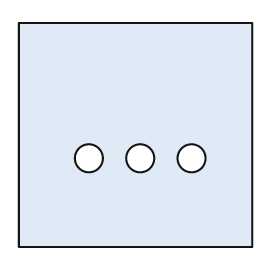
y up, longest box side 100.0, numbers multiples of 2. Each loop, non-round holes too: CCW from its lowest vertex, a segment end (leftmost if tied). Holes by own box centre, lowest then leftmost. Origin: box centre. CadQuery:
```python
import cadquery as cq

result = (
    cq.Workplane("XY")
    .moveTo(-50.0, -48.0)
    .lineTo(50.0, -48.0)
    .lineTo(50.0, 48.0)
    .lineTo(-50.0, 48.0)
    .close()
    .moveTo(-20.0, -10.0)
    .circle(6.0)
    .moveTo(2.0, -10.0)
    .circle(6.0)
    .moveTo(24.0, -10.0)
    .circle(6.0)
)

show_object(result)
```